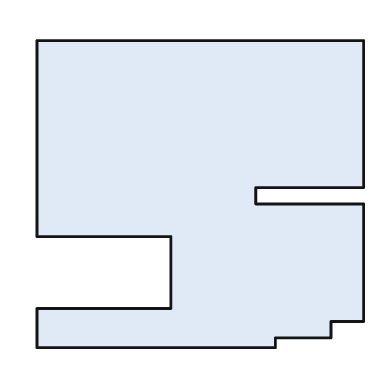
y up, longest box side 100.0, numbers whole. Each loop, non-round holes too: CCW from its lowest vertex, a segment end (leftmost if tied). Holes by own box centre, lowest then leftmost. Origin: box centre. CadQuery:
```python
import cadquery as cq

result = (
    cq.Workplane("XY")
    .moveTo(-50.0, -47.0)
    .lineTo(23.0, -47.0)
    .lineTo(23.0, -44.0)
    .lineTo(40.0, -44.0)
    .lineTo(40.0, -39.0)
    .lineTo(50.0, -39.0)
    .lineTo(50.0, -3.0)
    .lineTo(17.0, -3.0)
    .lineTo(17.0, 2.0)
    .lineTo(50.0, 2.0)
    .lineTo(50.0, 47.0)
    .lineTo(-50.0, 47.0)
    .lineTo(-50.0, -13.0)
    .lineTo(-9.0, -13.0)
    .lineTo(-9.0, -35.0)
    .lineTo(-50.0, -35.0)
    .close()
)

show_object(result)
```